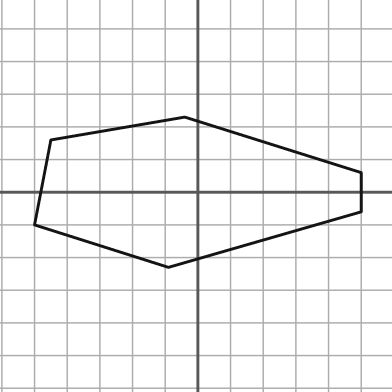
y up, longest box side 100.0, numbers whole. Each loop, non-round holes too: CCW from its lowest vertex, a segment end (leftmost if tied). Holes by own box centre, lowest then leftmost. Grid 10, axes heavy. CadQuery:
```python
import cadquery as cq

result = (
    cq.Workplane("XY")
    .moveTo(-9.0, -23.0)
    .lineTo(50.0, -6.0)
    .lineTo(50.0, 6.0)
    .lineTo(-4.0, 23.0)
    .lineTo(-45.0, 16.0)
    .lineTo(-50.0, -10.0)
    .close()
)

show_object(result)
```